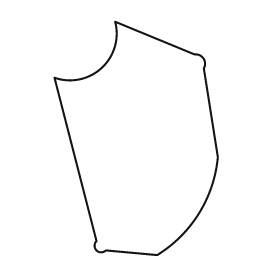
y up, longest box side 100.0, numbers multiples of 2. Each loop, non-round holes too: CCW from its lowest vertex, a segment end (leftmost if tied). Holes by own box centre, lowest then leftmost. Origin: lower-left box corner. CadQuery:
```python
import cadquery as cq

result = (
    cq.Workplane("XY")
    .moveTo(44.0, 0.0)
    .threePointArc((62.0, 18.0), (70.0, 42.0))
    .lineTo(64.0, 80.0)
    .threePointArc((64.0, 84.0), (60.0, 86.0))
    .lineTo(26.0, 100.0)
    .threePointArc((20.0, 80.0), (0.0, 76.0))
    .lineTo(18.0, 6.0)
    .threePointArc((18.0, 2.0), (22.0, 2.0))
    .close()
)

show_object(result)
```